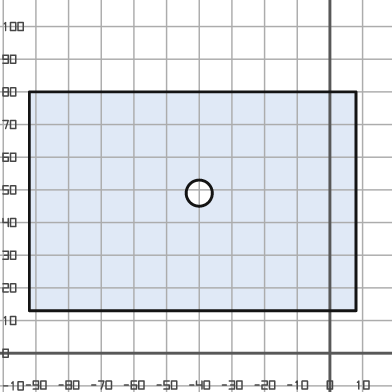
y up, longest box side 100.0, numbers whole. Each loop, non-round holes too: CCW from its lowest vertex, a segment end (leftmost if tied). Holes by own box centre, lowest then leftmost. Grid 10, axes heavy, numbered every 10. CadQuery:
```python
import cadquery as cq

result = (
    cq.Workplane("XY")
    .moveTo(-92.0, 13.0)
    .lineTo(8.0, 13.0)
    .lineTo(8.0, 80.0)
    .lineTo(-92.0, 80.0)
    .close()
    .moveTo(-40.0, 49.0)
    .circle(4.0)
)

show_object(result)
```